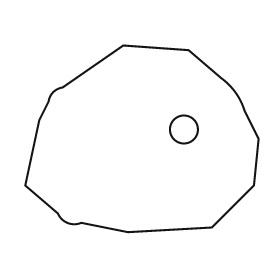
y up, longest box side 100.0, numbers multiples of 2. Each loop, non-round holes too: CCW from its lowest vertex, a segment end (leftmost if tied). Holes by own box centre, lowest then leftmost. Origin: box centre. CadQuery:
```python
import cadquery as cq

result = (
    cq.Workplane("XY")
    .moveTo(-6.0, -40.0)
    .lineTo(30.0, -38.0)
    .lineTo(48.0, -20.0)
    .lineTo(50.0, 0.0)
    .lineTo(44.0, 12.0)
    .threePointArc((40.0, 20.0), (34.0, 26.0))
    .lineTo(20.0, 38.0)
    .lineTo(-8.0, 40.0)
    .lineTo(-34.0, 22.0)
    .threePointArc((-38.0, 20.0), (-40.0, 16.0))
    .lineTo(-44.0, 8.0)
    .lineTo(-50.0, -20.0)
    .lineTo(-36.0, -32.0)
    .threePointArc((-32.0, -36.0), (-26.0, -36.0))
    .close()
    .moveTo(18.0, 4.0)
    .circle(6.0)
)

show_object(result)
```